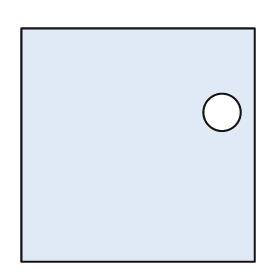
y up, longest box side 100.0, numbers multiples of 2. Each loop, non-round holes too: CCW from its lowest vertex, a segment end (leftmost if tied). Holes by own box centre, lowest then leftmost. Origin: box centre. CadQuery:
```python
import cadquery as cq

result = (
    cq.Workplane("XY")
    .moveTo(-50.0, -50.0)
    .lineTo(50.0, -50.0)
    .lineTo(50.0, 50.0)
    .lineTo(-50.0, 50.0)
    .close()
    .moveTo(36.0, 14.0)
    .circle(8.0)
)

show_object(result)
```